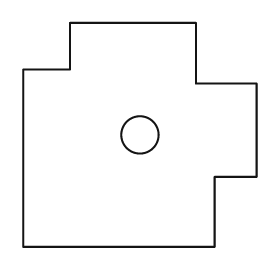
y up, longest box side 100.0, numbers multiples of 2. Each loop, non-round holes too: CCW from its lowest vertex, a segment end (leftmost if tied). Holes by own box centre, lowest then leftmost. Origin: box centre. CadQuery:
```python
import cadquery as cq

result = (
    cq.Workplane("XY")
    .moveTo(-50.0, -48.0)
    .lineTo(32.0, -48.0)
    .lineTo(32.0, -18.0)
    .lineTo(50.0, -18.0)
    .lineTo(50.0, 22.0)
    .lineTo(24.0, 22.0)
    .lineTo(24.0, 48.0)
    .lineTo(-30.0, 48.0)
    .lineTo(-30.0, 28.0)
    .lineTo(-50.0, 28.0)
    .close()
    .moveTo(0.0, 0.0)
    .circle(8.0)
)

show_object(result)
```